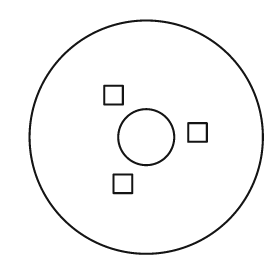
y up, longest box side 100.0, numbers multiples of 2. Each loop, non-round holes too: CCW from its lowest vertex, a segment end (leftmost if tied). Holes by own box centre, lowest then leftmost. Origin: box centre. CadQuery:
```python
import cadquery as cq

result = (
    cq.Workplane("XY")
    .moveTo(0.0, 0.0)
    .circle(50.0)
    .moveTo(-14.0, -24.0)
    .lineTo(-6.0, -24.0)
    .lineTo(-6.0, -16.0)
    .lineTo(-14.0, -16.0)
    .close()
    .moveTo(0.0, 0.0)
    .circle(12.0)
    .moveTo(18.0, -2.0)
    .lineTo(26.0, -2.0)
    .lineTo(26.0, 6.0)
    .lineTo(18.0, 6.0)
    .close()
    .moveTo(-18.0, 14.0)
    .lineTo(-10.0, 14.0)
    .lineTo(-10.0, 22.0)
    .lineTo(-18.0, 22.0)
    .close()
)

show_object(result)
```